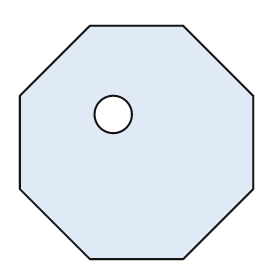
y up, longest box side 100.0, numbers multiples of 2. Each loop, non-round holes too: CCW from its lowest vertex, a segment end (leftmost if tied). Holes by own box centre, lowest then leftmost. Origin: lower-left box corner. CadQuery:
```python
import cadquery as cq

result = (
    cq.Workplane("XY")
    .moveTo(30.0, 0.0)
    .lineTo(70.0, 0.0)
    .lineTo(100.0, 30.0)
    .lineTo(100.0, 70.0)
    .lineTo(70.0, 100.0)
    .lineTo(30.0, 100.0)
    .lineTo(0.0, 70.0)
    .lineTo(0.0, 30.0)
    .close()
    .moveTo(40.0, 62.0)
    .circle(8.0)
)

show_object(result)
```